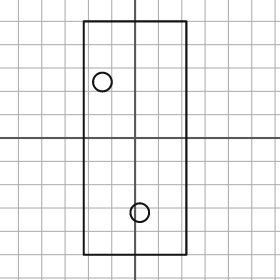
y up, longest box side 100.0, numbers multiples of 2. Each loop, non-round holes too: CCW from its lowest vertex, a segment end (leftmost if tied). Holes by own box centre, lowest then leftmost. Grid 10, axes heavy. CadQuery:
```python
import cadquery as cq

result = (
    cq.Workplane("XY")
    .moveTo(-22.0, -50.0)
    .lineTo(22.0, -50.0)
    .lineTo(22.0, 50.0)
    .lineTo(-22.0, 50.0)
    .close()
    .moveTo(2.0, -32.0)
    .circle(4.0)
    .moveTo(-14.0, 24.0)
    .circle(4.0)
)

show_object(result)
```